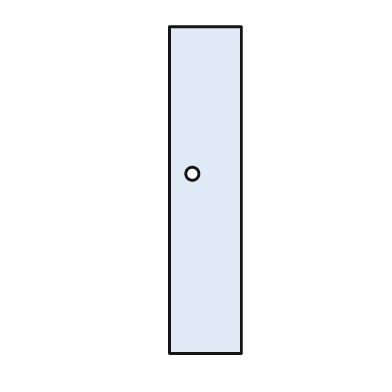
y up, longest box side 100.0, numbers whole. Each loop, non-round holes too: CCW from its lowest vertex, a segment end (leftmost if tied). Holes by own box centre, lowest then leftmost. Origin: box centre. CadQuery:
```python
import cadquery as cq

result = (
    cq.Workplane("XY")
    .moveTo(-11.0, -50.0)
    .lineTo(11.0, -50.0)
    .lineTo(11.0, 50.0)
    .lineTo(-11.0, 50.0)
    .close()
    .moveTo(-4.0, 5.0)
    .circle(2.0)
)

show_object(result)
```